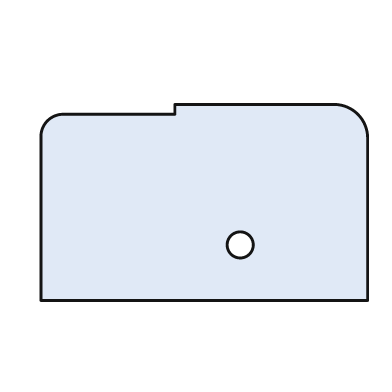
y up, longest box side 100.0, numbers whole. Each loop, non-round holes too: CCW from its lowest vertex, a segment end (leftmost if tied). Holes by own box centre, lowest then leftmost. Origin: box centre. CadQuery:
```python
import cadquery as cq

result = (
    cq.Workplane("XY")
    .moveTo(-50.0, -30.0)
    .lineTo(50.0, -30.0)
    .lineTo(50.0, 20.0)
    .threePointArc((47.0, 27.0), (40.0, 30.0))
    .lineTo(-9.0, 30.0)
    .lineTo(-9.0, 27.0)
    .lineTo(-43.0, 27.0)
    .threePointArc((-48.0, 25.0), (-50.0, 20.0))
    .close()
    .moveTo(11.0, -13.0)
    .circle(4.0)
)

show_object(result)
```